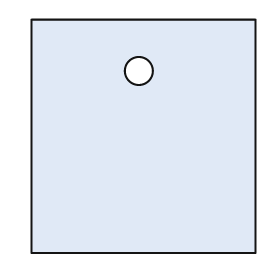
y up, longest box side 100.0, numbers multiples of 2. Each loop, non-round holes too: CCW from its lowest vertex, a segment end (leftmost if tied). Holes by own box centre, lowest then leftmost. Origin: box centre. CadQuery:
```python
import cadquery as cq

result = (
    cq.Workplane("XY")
    .moveTo(-48.0, -50.0)
    .lineTo(48.0, -50.0)
    .lineTo(48.0, 50.0)
    .lineTo(-48.0, 50.0)
    .close()
    .moveTo(-2.0, 28.0)
    .circle(6.0)
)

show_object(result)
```